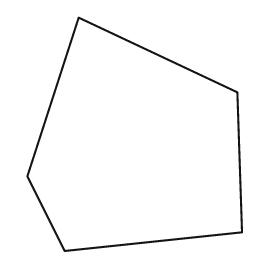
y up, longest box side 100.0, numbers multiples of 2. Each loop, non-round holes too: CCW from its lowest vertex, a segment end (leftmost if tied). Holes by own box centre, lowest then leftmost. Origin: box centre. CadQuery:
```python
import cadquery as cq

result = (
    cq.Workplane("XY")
    .moveTo(-30.0, -50.0)
    .lineTo(46.0, -42.0)
    .lineTo(44.0, 18.0)
    .lineTo(-24.0, 50.0)
    .lineTo(-46.0, -18.0)
    .close()
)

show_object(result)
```